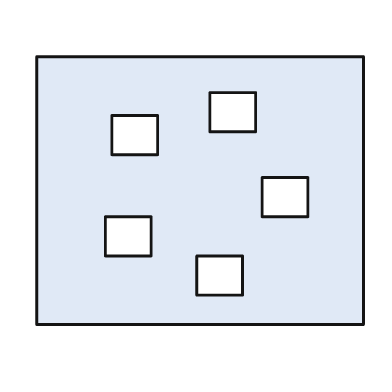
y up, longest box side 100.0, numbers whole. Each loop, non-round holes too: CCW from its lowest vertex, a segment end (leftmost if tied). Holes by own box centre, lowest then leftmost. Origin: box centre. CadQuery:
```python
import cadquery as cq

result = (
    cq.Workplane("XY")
    .moveTo(-50.0, -41.0)
    .lineTo(50.0, -41.0)
    .lineTo(50.0, 41.0)
    .lineTo(-50.0, 41.0)
    .close()
    .moveTo(-1.0, -32.0)
    .lineTo(13.0, -32.0)
    .lineTo(13.0, -20.0)
    .lineTo(-1.0, -20.0)
    .close()
    .moveTo(-29.0, -20.0)
    .lineTo(-15.0, -20.0)
    .lineTo(-15.0, -8.0)
    .lineTo(-29.0, -8.0)
    .close()
    .moveTo(19.0, -8.0)
    .lineTo(33.0, -8.0)
    .lineTo(33.0, 4.0)
    .lineTo(19.0, 4.0)
    .close()
    .moveTo(-27.0, 11.0)
    .lineTo(-13.0, 11.0)
    .lineTo(-13.0, 23.0)
    .lineTo(-27.0, 23.0)
    .close()
    .moveTo(3.0, 18.0)
    .lineTo(17.0, 18.0)
    .lineTo(17.0, 30.0)
    .lineTo(3.0, 30.0)
    .close()
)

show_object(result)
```